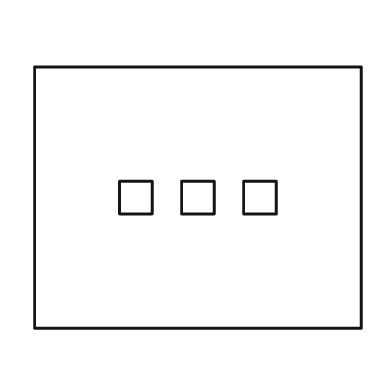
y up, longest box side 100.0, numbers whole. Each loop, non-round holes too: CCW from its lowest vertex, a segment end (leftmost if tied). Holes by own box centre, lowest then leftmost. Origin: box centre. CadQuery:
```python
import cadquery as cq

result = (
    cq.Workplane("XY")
    .moveTo(-50.0, -40.0)
    .lineTo(50.0, -40.0)
    .lineTo(50.0, 40.0)
    .lineTo(-50.0, 40.0)
    .close()
    .moveTo(-24.0, -5.0)
    .lineTo(-14.0, -5.0)
    .lineTo(-14.0, 5.0)
    .lineTo(-24.0, 5.0)
    .close()
    .moveTo(-5.0, -5.0)
    .lineTo(5.0, -5.0)
    .lineTo(5.0, 5.0)
    .lineTo(-5.0, 5.0)
    .close()
    .moveTo(14.0, -5.0)
    .lineTo(24.0, -5.0)
    .lineTo(24.0, 5.0)
    .lineTo(14.0, 5.0)
    .close()
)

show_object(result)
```